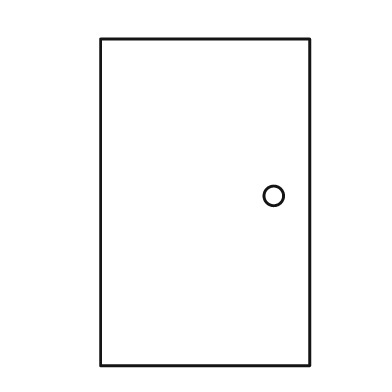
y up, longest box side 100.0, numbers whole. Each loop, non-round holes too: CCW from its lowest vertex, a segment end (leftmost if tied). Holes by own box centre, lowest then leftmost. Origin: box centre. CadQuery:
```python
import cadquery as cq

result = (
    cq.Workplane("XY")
    .moveTo(-32.0, -50.0)
    .lineTo(32.0, -50.0)
    .lineTo(32.0, 50.0)
    .lineTo(-32.0, 50.0)
    .close()
    .moveTo(21.0, 2.0)
    .circle(3.0)
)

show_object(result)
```